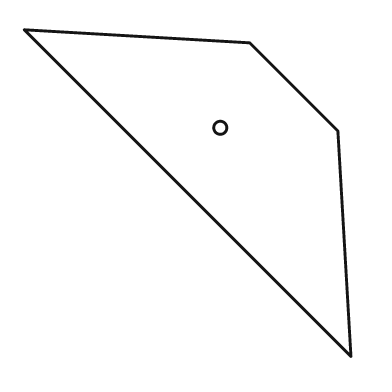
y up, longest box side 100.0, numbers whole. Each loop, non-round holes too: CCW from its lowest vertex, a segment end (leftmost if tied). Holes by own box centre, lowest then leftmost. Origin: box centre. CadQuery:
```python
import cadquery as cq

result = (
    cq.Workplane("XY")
    .moveTo(50.0, -50.0)
    .lineTo(46.0, 19.0)
    .lineTo(19.0, 46.0)
    .lineTo(-50.0, 50.0)
    .close()
    .moveTo(10.0, 20.0)
    .circle(2.0)
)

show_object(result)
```